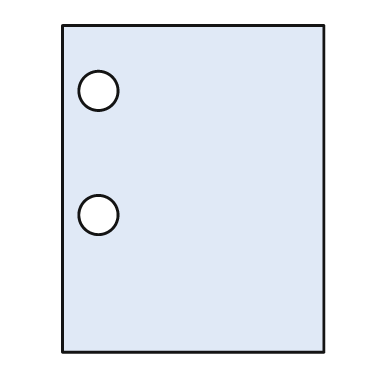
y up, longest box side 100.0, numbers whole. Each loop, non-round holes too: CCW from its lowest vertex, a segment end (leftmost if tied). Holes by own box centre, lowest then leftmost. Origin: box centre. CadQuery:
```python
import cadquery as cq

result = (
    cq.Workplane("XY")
    .moveTo(-40.0, -50.0)
    .lineTo(40.0, -50.0)
    .lineTo(40.0, 50.0)
    .lineTo(-40.0, 50.0)
    .close()
    .moveTo(-29.0, -8.0)
    .circle(6.0)
    .moveTo(-29.0, 30.0)
    .circle(6.0)
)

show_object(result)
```